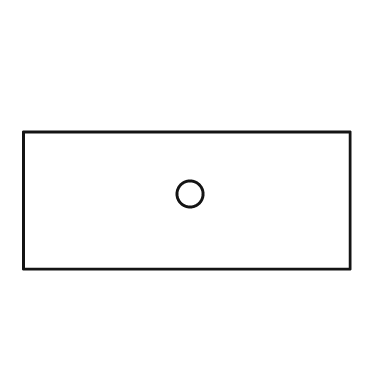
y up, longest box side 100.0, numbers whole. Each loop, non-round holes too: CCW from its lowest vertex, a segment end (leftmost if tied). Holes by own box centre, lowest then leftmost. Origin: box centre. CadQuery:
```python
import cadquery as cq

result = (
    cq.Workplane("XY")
    .moveTo(-50.0, -21.0)
    .lineTo(50.0, -21.0)
    .lineTo(50.0, 21.0)
    .lineTo(-50.0, 21.0)
    .close()
    .moveTo(1.0, 2.0)
    .circle(4.0)
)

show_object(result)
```